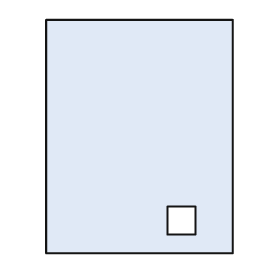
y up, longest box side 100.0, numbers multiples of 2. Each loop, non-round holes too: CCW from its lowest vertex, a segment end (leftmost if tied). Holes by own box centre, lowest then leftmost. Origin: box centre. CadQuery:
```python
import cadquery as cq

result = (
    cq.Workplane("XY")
    .moveTo(-40.0, -50.0)
    .lineTo(40.0, -50.0)
    .lineTo(40.0, 50.0)
    .lineTo(-40.0, 50.0)
    .close()
    .moveTo(12.0, -42.0)
    .lineTo(24.0, -42.0)
    .lineTo(24.0, -30.0)
    .lineTo(12.0, -30.0)
    .close()
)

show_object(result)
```